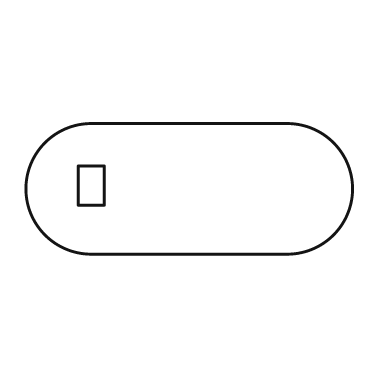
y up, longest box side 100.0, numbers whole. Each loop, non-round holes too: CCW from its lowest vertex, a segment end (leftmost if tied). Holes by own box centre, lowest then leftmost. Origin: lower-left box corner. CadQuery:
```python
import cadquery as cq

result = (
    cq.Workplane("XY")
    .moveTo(20.0, 0.0)
    .lineTo(80.0, 0.0)
    .threePointArc((100.0, 20.0), (80.0, 40.0))
    .lineTo(20.0, 40.0)
    .threePointArc((0.0, 20.0), (20.0, 0.0))
    .close()
    .moveTo(16.0, 15.0)
    .lineTo(24.0, 15.0)
    .lineTo(24.0, 27.0)
    .lineTo(16.0, 27.0)
    .close()
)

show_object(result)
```